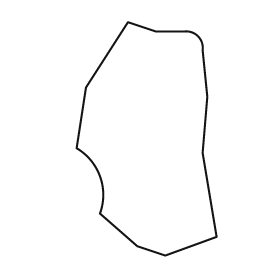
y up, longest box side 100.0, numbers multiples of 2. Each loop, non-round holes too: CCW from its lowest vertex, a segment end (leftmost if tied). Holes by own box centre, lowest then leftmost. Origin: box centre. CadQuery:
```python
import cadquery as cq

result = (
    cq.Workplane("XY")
    .moveTo(8.0, -50.0)
    .lineTo(30.0, -42.0)
    .lineTo(24.0, -6.0)
    .lineTo(26.0, 18.0)
    .lineTo(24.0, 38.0)
    .threePointArc((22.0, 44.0), (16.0, 46.0))
    .lineTo(4.0, 46.0)
    .lineTo(-8.0, 50.0)
    .lineTo(-26.0, 22.0)
    .lineTo(-30.0, -4.0)
    .threePointArc((-20.0, -16.0), (-20.0, -32.0))
    .lineTo(-4.0, -46.0)
    .close()
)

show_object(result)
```